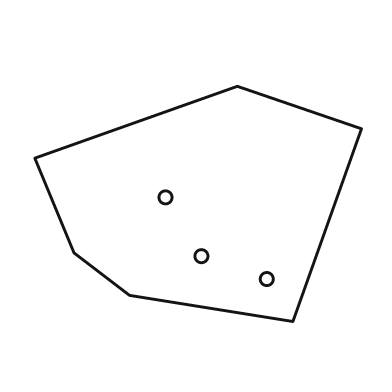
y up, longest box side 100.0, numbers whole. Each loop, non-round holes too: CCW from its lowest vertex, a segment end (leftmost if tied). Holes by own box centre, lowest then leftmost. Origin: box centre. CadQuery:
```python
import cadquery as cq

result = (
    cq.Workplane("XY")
    .moveTo(29.0, -36.0)
    .lineTo(50.0, 23.0)
    .lineTo(12.0, 36.0)
    .lineTo(-50.0, 14.0)
    .lineTo(-38.0, -15.0)
    .lineTo(-21.0, -28.0)
    .close()
    .moveTo(21.0, -23.0)
    .circle(2.0)
    .moveTo(1.0, -16.0)
    .circle(2.0)
    .moveTo(-10.0, 2.0)
    .circle(2.0)
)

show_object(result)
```